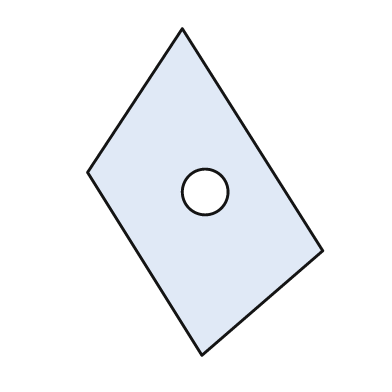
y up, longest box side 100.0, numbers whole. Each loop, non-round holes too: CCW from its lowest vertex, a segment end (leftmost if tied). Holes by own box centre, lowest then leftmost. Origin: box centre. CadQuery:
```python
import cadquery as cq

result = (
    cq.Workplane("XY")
    .moveTo(-1.0, -50.0)
    .lineTo(36.0, -18.0)
    .lineTo(-7.0, 50.0)
    .lineTo(-36.0, 6.0)
    .close()
    .moveTo(0.0, 0.0)
    .circle(7.0)
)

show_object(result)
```